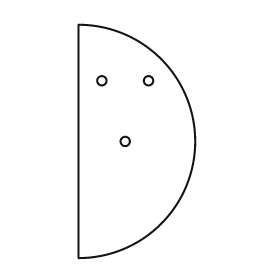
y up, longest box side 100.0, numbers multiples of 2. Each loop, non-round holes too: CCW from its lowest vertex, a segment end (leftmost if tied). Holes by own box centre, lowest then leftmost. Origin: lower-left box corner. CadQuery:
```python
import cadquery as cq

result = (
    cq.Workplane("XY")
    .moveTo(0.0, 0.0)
    .threePointArc((50.0, 50.0), (0.0, 100.0))
    .close()
    .moveTo(20.0, 50.0)
    .circle(2.0)
    .moveTo(10.0, 76.0)
    .circle(2.0)
    .moveTo(30.0, 76.0)
    .circle(2.0)
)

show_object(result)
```